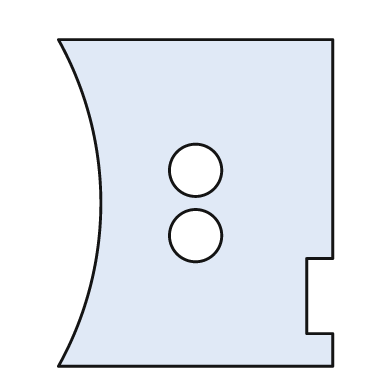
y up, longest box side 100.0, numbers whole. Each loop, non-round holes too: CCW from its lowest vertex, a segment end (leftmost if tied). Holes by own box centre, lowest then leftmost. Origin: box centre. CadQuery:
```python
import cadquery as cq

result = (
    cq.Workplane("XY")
    .moveTo(-42.0, -50.0)
    .lineTo(42.0, -50.0)
    .lineTo(42.0, -40.0)
    .lineTo(34.0, -40.0)
    .lineTo(34.0, -17.0)
    .lineTo(42.0, -17.0)
    .lineTo(42.0, 50.0)
    .lineTo(-42.0, 50.0)
    .threePointArc((-29.0, 0.0), (-42.0, -50.0))
    .close()
    .moveTo(0.0, -10.0)
    .circle(8.0)
    .moveTo(0.0, 10.0)
    .circle(8.0)
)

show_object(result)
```